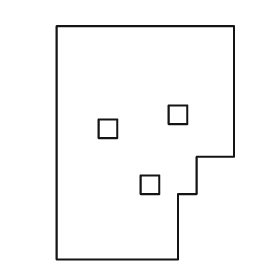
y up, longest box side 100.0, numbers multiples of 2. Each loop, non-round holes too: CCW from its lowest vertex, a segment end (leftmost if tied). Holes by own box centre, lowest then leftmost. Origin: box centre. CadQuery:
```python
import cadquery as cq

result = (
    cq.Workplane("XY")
    .moveTo(-38.0, -50.0)
    .lineTo(14.0, -50.0)
    .lineTo(14.0, -22.0)
    .lineTo(22.0, -22.0)
    .lineTo(22.0, -6.0)
    .lineTo(38.0, -6.0)
    .lineTo(38.0, 50.0)
    .lineTo(-38.0, 50.0)
    .close()
    .moveTo(-2.0, -22.0)
    .lineTo(6.0, -22.0)
    .lineTo(6.0, -14.0)
    .lineTo(-2.0, -14.0)
    .close()
    .moveTo(-20.0, 2.0)
    .lineTo(-12.0, 2.0)
    .lineTo(-12.0, 10.0)
    .lineTo(-20.0, 10.0)
    .close()
    .moveTo(10.0, 8.0)
    .lineTo(18.0, 8.0)
    .lineTo(18.0, 16.0)
    .lineTo(10.0, 16.0)
    .close()
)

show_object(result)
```